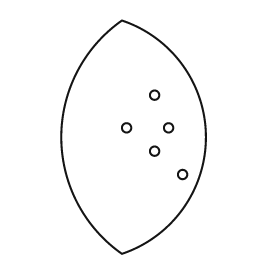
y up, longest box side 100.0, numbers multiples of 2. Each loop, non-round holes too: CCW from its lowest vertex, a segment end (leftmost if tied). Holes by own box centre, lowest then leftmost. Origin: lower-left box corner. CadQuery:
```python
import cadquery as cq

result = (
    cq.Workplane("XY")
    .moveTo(26.0, 0.0)
    .threePointArc((62.0, 50.0), (26.0, 100.0))
    .threePointArc((0.0, 50.0), (26.0, 0.0))
    .close()
    .moveTo(52.0, 34.0)
    .circle(2.0)
    .moveTo(40.0, 44.0)
    .circle(2.0)
    .moveTo(28.0, 54.0)
    .circle(2.0)
    .moveTo(46.0, 54.0)
    .circle(2.0)
    .moveTo(40.0, 68.0)
    .circle(2.0)
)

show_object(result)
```